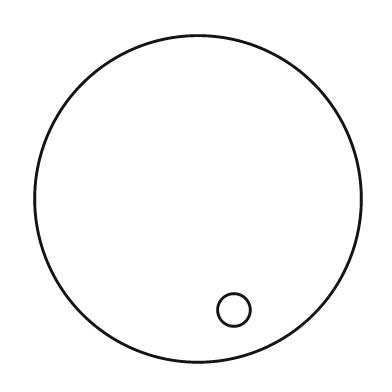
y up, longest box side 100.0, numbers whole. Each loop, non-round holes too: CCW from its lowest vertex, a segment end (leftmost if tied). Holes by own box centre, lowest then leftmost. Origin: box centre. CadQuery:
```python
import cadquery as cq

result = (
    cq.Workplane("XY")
    .moveTo(0.0, 0.0)
    .circle(50.0)
    .moveTo(11.0, -34.0)
    .circle(5.0)
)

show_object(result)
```